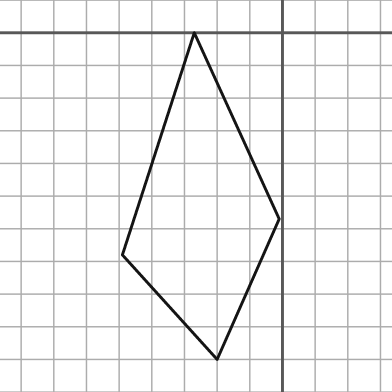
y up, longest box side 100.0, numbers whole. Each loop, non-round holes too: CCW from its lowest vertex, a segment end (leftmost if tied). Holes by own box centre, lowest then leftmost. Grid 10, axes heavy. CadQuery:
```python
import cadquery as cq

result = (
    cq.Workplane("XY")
    .moveTo(-20.0, -100.0)
    .lineTo(-1.0, -57.0)
    .lineTo(-27.0, 0.0)
    .lineTo(-49.0, -68.0)
    .close()
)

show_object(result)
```